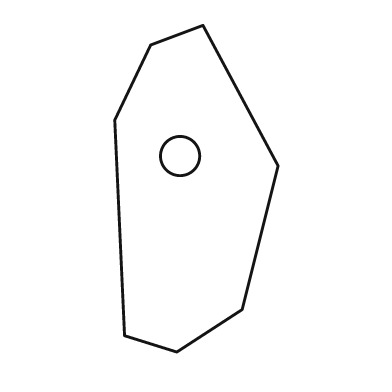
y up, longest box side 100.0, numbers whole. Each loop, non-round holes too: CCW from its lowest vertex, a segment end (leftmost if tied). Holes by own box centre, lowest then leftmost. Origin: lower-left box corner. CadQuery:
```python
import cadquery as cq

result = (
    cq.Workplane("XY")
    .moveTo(19.0, 0.0)
    .lineTo(39.0, 13.0)
    .lineTo(50.0, 57.0)
    .lineTo(27.0, 100.0)
    .lineTo(11.0, 94.0)
    .lineTo(0.0, 71.0)
    .lineTo(3.0, 5.0)
    .close()
    .moveTo(20.0, 60.0)
    .circle(6.0)
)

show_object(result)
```